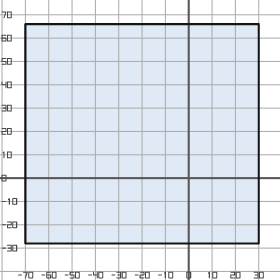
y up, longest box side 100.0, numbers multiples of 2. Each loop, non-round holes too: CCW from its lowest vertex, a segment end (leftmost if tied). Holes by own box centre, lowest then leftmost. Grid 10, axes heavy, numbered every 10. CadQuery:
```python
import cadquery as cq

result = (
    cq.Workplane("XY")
    .moveTo(-70.0, -28.0)
    .lineTo(30.0, -28.0)
    .lineTo(30.0, 66.0)
    .lineTo(-70.0, 66.0)
    .close()
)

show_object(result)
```